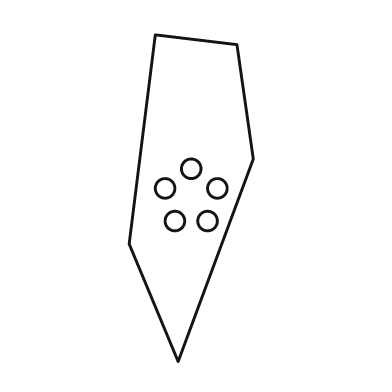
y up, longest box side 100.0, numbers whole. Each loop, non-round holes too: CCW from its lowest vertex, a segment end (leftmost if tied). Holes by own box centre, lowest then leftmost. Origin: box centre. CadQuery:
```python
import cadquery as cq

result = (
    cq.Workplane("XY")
    .moveTo(-4.0, -50.0)
    .lineTo(19.0, 12.0)
    .lineTo(14.0, 47.0)
    .lineTo(-11.0, 50.0)
    .lineTo(-19.0, -14.0)
    .close()
    .moveTo(-5.0, -7.0)
    .circle(3.0)
    .moveTo(5.0, -7.0)
    .circle(3.0)
    .moveTo(-8.0, 3.0)
    .circle(3.0)
    .moveTo(8.0, 3.0)
    .circle(3.0)
    .moveTo(0.0, 9.0)
    .circle(3.0)
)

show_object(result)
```